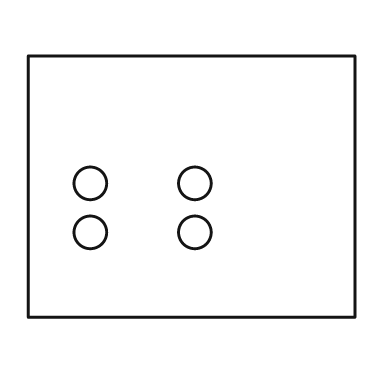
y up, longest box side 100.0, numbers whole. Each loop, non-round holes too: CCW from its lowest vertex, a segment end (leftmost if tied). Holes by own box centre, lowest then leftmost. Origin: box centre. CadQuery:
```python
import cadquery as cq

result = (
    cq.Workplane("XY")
    .moveTo(-50.0, -40.0)
    .lineTo(50.0, -40.0)
    .lineTo(50.0, 40.0)
    .lineTo(-50.0, 40.0)
    .close()
    .moveTo(-31.0, -14.0)
    .circle(5.0)
    .moveTo(1.0, -14.0)
    .circle(5.0)
    .moveTo(-31.0, 1.0)
    .circle(5.0)
    .moveTo(1.0, 1.0)
    .circle(5.0)
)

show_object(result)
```